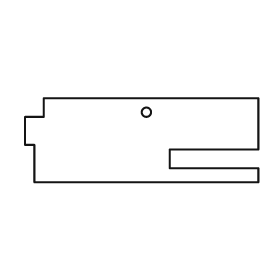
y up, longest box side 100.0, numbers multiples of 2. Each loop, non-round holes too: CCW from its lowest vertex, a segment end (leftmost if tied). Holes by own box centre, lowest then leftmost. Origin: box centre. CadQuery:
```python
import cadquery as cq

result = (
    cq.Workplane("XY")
    .moveTo(-46.0, -18.0)
    .lineTo(50.0, -18.0)
    .lineTo(50.0, -12.0)
    .lineTo(12.0, -12.0)
    .lineTo(12.0, -4.0)
    .lineTo(50.0, -4.0)
    .lineTo(50.0, 18.0)
    .lineTo(-42.0, 18.0)
    .lineTo(-42.0, 10.0)
    .lineTo(-50.0, 10.0)
    .lineTo(-50.0, -2.0)
    .lineTo(-46.0, -2.0)
    .close()
    .moveTo(2.0, 12.0)
    .circle(2.0)
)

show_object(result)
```